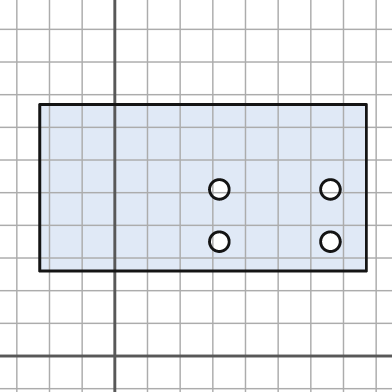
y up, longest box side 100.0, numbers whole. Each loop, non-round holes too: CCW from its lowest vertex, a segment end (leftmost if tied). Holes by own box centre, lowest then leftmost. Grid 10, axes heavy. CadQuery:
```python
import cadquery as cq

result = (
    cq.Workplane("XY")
    .moveTo(-23.0, 26.0)
    .lineTo(77.0, 26.0)
    .lineTo(77.0, 77.0)
    .lineTo(-23.0, 77.0)
    .close()
    .moveTo(32.0, 35.0)
    .circle(3.0)
    .moveTo(66.0, 35.0)
    .circle(3.0)
    .moveTo(32.0, 51.0)
    .circle(3.0)
    .moveTo(66.0, 51.0)
    .circle(3.0)
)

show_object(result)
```